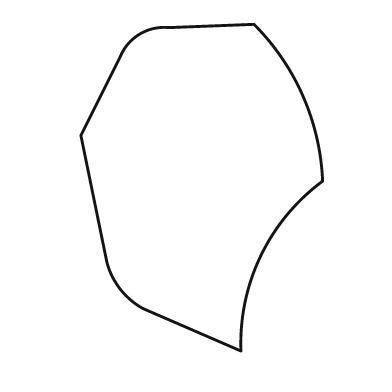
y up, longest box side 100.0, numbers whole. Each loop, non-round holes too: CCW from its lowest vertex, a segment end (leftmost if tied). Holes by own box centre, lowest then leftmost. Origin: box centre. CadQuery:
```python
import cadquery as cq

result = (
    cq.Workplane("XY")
    .moveTo(12.0, -50.0)
    .threePointArc((18.0, -21.0), (37.0, 2.0))
    .threePointArc((31.0, 28.0), (16.0, 50.0))
    .lineTo(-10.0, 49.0)
    .threePointArc((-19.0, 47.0), (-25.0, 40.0))
    .lineTo(-37.0, 16.0)
    .lineTo(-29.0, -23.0)
    .threePointArc((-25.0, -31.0), (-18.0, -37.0))
    .close()
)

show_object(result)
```